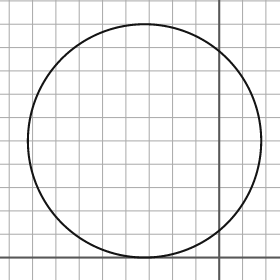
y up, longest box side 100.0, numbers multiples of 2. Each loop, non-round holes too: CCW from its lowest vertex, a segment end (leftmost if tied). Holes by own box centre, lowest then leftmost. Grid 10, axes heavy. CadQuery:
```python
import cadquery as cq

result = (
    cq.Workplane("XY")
    .moveTo(-32.0, 50.0)
    .circle(50.0)
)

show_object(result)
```